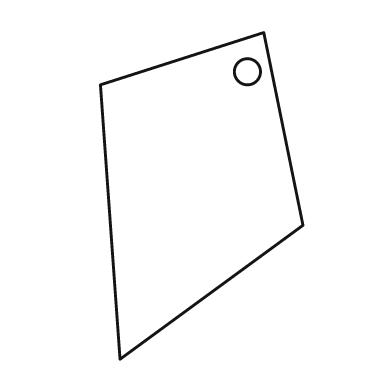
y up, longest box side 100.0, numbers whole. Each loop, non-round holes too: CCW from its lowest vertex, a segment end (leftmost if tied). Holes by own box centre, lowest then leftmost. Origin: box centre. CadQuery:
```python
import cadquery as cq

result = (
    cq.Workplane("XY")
    .moveTo(-25.0, -50.0)
    .lineTo(31.0, -9.0)
    .lineTo(19.0, 50.0)
    .lineTo(-31.0, 34.0)
    .close()
    .moveTo(14.0, 38.0)
    .circle(4.0)
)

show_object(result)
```